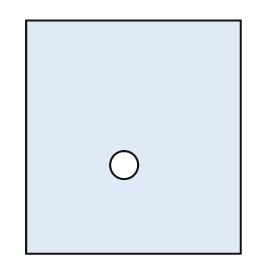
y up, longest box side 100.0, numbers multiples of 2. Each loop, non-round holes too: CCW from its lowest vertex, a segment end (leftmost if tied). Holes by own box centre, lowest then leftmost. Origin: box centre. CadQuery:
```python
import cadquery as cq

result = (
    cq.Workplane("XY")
    .moveTo(-46.0, -50.0)
    .lineTo(46.0, -50.0)
    .lineTo(46.0, 50.0)
    .lineTo(-46.0, 50.0)
    .close()
    .moveTo(-4.0, -12.0)
    .circle(6.0)
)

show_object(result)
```